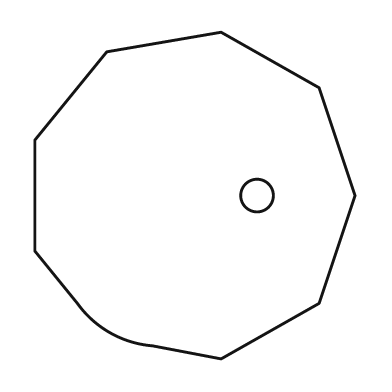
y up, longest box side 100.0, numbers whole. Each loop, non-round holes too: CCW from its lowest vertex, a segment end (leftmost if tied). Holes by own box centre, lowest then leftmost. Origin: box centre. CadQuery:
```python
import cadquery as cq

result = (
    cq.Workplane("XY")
    .moveTo(8.0, -50.0)
    .lineTo(38.0, -33.0)
    .lineTo(49.0, 0.0)
    .lineTo(38.0, 33.0)
    .lineTo(8.0, 50.0)
    .lineTo(-27.0, 44.0)
    .lineTo(-49.0, 17.0)
    .lineTo(-49.0, -17.0)
    .lineTo(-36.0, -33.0)
    .threePointArc((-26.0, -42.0), (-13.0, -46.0))
    .close()
    .moveTo(19.0, 0.0)
    .circle(5.0)
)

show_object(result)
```